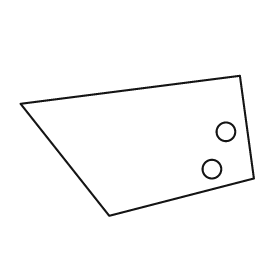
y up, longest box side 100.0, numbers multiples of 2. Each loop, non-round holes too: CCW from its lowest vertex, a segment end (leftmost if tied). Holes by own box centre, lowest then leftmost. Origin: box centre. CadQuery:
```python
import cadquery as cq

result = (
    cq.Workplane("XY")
    .moveTo(-12.0, -30.0)
    .lineTo(50.0, -14.0)
    .lineTo(44.0, 30.0)
    .lineTo(-50.0, 18.0)
    .close()
    .moveTo(32.0, -10.0)
    .circle(4.0)
    .moveTo(38.0, 6.0)
    .circle(4.0)
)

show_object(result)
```